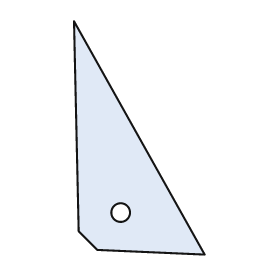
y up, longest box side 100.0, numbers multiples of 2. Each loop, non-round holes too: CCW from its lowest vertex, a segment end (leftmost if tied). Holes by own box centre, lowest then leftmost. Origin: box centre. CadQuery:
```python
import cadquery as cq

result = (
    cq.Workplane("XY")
    .moveTo(28.0, -50.0)
    .lineTo(-28.0, 50.0)
    .lineTo(-26.0, -40.0)
    .lineTo(-18.0, -48.0)
    .close()
    .moveTo(-8.0, -32.0)
    .circle(4.0)
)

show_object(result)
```